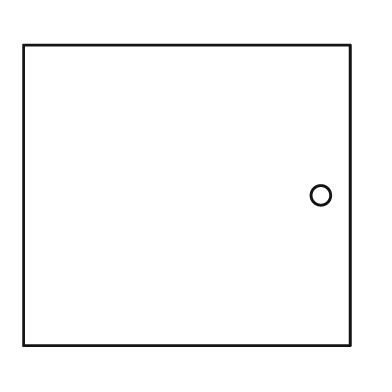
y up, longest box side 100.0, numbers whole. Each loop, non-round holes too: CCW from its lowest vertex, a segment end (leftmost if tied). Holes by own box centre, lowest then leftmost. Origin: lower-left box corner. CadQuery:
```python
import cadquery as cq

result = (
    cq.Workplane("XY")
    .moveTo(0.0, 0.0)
    .lineTo(100.0, 0.0)
    .lineTo(100.0, 92.0)
    .lineTo(0.0, 92.0)
    .close()
    .moveTo(91.0, 46.0)
    .circle(3.0)
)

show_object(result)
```